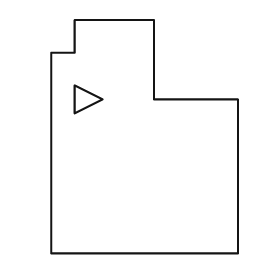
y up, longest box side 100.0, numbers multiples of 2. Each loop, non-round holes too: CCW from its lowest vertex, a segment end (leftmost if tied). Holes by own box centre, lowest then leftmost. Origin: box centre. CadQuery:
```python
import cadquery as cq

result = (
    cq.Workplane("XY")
    .moveTo(-40.0, -50.0)
    .lineTo(40.0, -50.0)
    .lineTo(40.0, 16.0)
    .lineTo(4.0, 16.0)
    .lineTo(4.0, 50.0)
    .lineTo(-30.0, 50.0)
    .lineTo(-30.0, 36.0)
    .lineTo(-40.0, 36.0)
    .close()
    .moveTo(-30.0, 10.0)
    .lineTo(-18.0, 16.0)
    .lineTo(-30.0, 22.0)
    .close()
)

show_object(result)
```